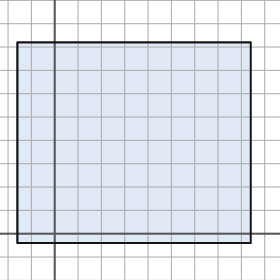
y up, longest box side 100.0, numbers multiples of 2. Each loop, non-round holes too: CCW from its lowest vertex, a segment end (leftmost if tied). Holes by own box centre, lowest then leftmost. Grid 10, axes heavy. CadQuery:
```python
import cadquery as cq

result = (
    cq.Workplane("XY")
    .moveTo(-16.0, -4.0)
    .lineTo(84.0, -4.0)
    .lineTo(84.0, 82.0)
    .lineTo(-16.0, 82.0)
    .close()
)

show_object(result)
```